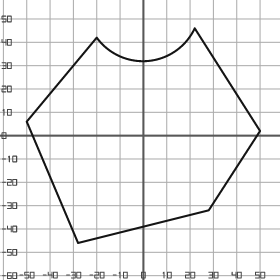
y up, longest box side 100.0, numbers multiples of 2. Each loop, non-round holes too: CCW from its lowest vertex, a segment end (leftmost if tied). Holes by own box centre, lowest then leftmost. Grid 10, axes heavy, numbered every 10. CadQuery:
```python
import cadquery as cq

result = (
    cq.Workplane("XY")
    .moveTo(-28.0, -46.0)
    .lineTo(28.0, -32.0)
    .lineTo(50.0, 2.0)
    .lineTo(22.0, 46.0)
    .threePointArc((2.0, 32.0), (-20.0, 42.0))
    .lineTo(-50.0, 6.0)
    .close()
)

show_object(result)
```